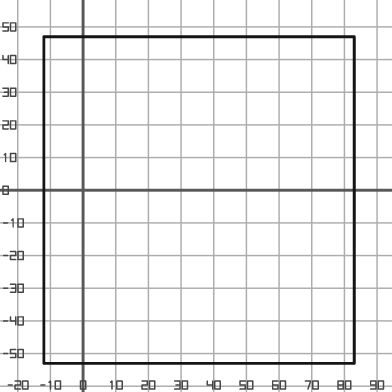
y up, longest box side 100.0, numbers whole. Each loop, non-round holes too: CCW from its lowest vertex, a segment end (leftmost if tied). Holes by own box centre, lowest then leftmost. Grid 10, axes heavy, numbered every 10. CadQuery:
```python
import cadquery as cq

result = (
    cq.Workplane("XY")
    .moveTo(-12.0, -53.0)
    .lineTo(83.0, -53.0)
    .lineTo(83.0, 47.0)
    .lineTo(-12.0, 47.0)
    .close()
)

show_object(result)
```